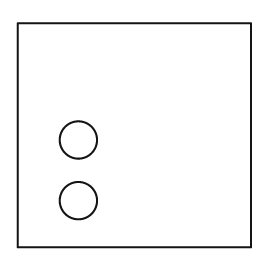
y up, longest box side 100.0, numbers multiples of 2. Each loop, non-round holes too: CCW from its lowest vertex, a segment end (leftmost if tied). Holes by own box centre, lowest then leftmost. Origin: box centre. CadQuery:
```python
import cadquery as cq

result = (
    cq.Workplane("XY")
    .moveTo(-50.0, -48.0)
    .lineTo(50.0, -48.0)
    .lineTo(50.0, 48.0)
    .lineTo(-50.0, 48.0)
    .close()
    .moveTo(-24.0, -28.0)
    .circle(8.0)
    .moveTo(-24.0, -2.0)
    .circle(8.0)
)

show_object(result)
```